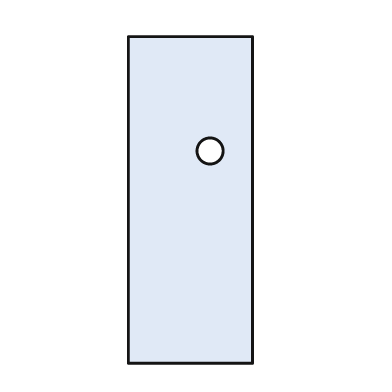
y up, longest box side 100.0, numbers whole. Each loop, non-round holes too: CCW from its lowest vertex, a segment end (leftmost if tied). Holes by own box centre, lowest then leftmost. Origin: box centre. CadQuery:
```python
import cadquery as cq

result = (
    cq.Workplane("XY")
    .moveTo(-19.0, -50.0)
    .lineTo(19.0, -50.0)
    .lineTo(19.0, 50.0)
    .lineTo(-19.0, 50.0)
    .close()
    .moveTo(6.0, 15.0)
    .circle(4.0)
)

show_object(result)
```